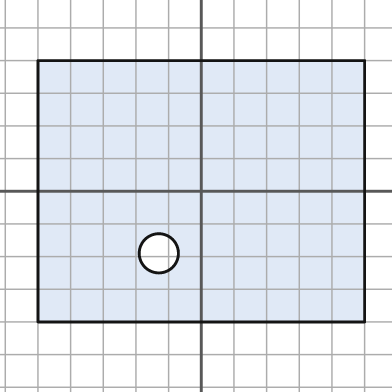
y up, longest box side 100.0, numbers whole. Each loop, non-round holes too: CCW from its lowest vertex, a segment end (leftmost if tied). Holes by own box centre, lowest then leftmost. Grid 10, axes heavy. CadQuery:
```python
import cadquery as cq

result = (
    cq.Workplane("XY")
    .moveTo(-50.0, -40.0)
    .lineTo(50.0, -40.0)
    .lineTo(50.0, 40.0)
    .lineTo(-50.0, 40.0)
    .close()
    .moveTo(-13.0, -19.0)
    .circle(6.0)
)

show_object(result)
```